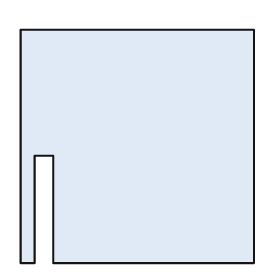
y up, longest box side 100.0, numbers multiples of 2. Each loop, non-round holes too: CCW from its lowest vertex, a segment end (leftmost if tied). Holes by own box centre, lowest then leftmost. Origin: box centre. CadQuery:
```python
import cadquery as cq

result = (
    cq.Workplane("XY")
    .moveTo(-50.0, -50.0)
    .lineTo(-44.0, -50.0)
    .lineTo(-44.0, -4.0)
    .lineTo(-36.0, -4.0)
    .lineTo(-36.0, -50.0)
    .lineTo(50.0, -50.0)
    .lineTo(50.0, 50.0)
    .lineTo(-50.0, 50.0)
    .close()
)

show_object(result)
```